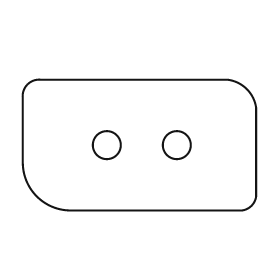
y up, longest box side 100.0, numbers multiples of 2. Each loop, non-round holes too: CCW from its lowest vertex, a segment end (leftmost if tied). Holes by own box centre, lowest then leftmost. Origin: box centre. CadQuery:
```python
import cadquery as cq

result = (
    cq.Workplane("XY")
    .moveTo(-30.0, -28.0)
    .lineTo(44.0, -28.0)
    .threePointArc((48.0, -26.0), (50.0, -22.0))
    .lineTo(50.0, 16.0)
    .threePointArc((46.0, 24.0), (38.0, 28.0))
    .lineTo(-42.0, 28.0)
    .threePointArc((-48.0, 26.0), (-50.0, 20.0))
    .lineTo(-50.0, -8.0)
    .threePointArc((-44.0, -22.0), (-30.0, -28.0))
    .close()
    .moveTo(-14.0, 0.0)
    .circle(6.0)
    .moveTo(16.0, 0.0)
    .circle(6.0)
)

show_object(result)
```